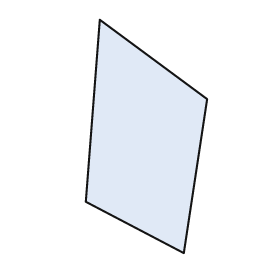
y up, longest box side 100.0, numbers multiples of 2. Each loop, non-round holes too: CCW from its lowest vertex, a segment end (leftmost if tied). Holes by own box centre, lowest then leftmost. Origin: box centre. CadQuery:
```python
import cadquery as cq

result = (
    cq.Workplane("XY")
    .moveTo(16.0, -50.0)
    .lineTo(26.0, 16.0)
    .lineTo(-20.0, 50.0)
    .lineTo(-26.0, -28.0)
    .close()
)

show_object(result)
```